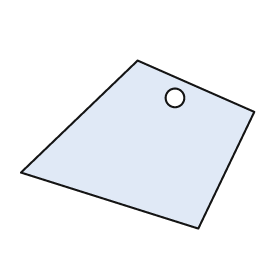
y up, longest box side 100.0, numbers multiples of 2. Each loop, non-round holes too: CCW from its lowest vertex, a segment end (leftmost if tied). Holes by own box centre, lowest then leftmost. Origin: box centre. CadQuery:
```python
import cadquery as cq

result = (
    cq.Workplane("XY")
    .moveTo(26.0, -36.0)
    .lineTo(50.0, 14.0)
    .lineTo(0.0, 36.0)
    .lineTo(-50.0, -12.0)
    .close()
    .moveTo(16.0, 20.0)
    .circle(4.0)
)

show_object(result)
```